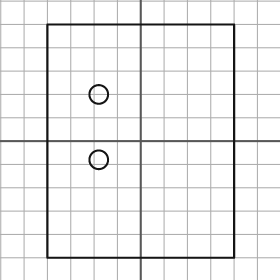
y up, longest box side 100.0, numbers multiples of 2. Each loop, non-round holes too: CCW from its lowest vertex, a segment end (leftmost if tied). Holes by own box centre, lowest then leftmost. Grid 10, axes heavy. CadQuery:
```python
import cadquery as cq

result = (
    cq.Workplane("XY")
    .moveTo(-40.0, -50.0)
    .lineTo(40.0, -50.0)
    .lineTo(40.0, 50.0)
    .lineTo(-40.0, 50.0)
    .close()
    .moveTo(-18.0, -8.0)
    .circle(4.0)
    .moveTo(-18.0, 20.0)
    .circle(4.0)
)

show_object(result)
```